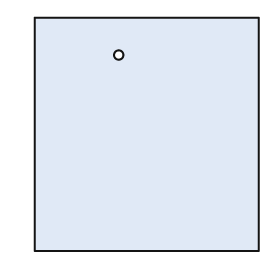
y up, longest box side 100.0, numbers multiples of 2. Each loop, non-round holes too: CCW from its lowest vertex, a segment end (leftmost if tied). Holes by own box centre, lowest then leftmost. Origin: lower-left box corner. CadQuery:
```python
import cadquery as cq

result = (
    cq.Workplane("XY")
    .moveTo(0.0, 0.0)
    .lineTo(96.0, 0.0)
    .lineTo(96.0, 100.0)
    .lineTo(0.0, 100.0)
    .close()
    .moveTo(36.0, 84.0)
    .circle(2.0)
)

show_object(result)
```